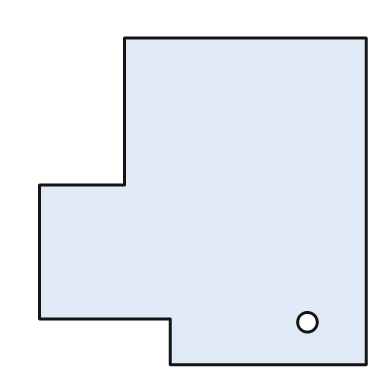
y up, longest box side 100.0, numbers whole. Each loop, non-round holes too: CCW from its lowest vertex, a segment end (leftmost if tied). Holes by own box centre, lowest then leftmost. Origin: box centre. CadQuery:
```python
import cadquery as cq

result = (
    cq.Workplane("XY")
    .moveTo(-10.0, -50.0)
    .lineTo(50.0, -50.0)
    .lineTo(50.0, 50.0)
    .lineTo(-24.0, 50.0)
    .lineTo(-24.0, 5.0)
    .lineTo(-50.0, 5.0)
    .lineTo(-50.0, -36.0)
    .lineTo(-10.0, -36.0)
    .close()
    .moveTo(32.0, -37.0)
    .circle(3.0)
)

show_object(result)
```